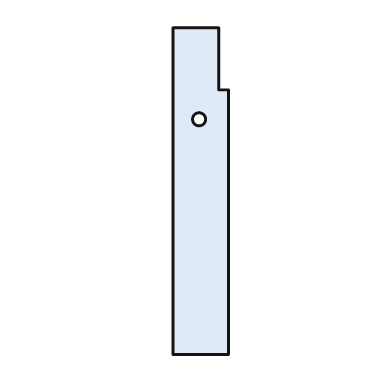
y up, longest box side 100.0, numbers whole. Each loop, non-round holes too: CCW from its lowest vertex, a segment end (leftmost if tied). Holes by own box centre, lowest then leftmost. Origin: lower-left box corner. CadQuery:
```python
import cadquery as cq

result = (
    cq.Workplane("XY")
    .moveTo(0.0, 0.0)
    .lineTo(17.0, 0.0)
    .lineTo(17.0, 81.0)
    .lineTo(14.0, 81.0)
    .lineTo(14.0, 100.0)
    .lineTo(0.0, 100.0)
    .close()
    .moveTo(8.0, 72.0)
    .circle(2.0)
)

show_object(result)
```